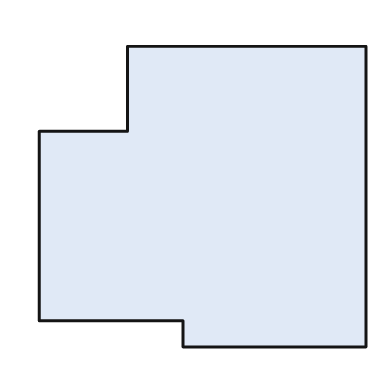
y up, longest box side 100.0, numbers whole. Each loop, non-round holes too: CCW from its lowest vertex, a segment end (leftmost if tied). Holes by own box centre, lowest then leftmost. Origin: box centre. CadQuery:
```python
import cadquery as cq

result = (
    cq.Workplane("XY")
    .moveTo(-6.0, -46.0)
    .lineTo(50.0, -46.0)
    .lineTo(50.0, 46.0)
    .lineTo(-23.0, 46.0)
    .lineTo(-23.0, 20.0)
    .lineTo(-50.0, 20.0)
    .lineTo(-50.0, -38.0)
    .lineTo(-6.0, -38.0)
    .close()
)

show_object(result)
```